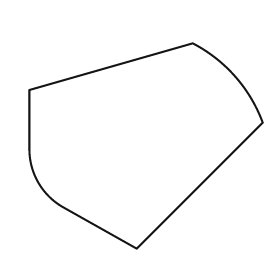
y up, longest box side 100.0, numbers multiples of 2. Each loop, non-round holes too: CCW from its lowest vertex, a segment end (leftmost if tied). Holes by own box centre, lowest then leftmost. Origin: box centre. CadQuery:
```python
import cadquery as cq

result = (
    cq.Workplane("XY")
    .moveTo(-4.0, -44.0)
    .lineTo(50.0, 10.0)
    .threePointArc((38.0, 30.0), (20.0, 44.0))
    .lineTo(-50.0, 24.0)
    .lineTo(-50.0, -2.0)
    .threePointArc((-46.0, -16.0), (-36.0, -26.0))
    .close()
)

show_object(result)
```